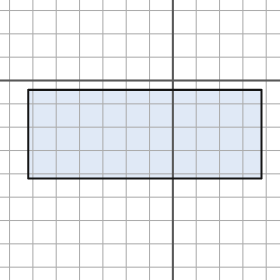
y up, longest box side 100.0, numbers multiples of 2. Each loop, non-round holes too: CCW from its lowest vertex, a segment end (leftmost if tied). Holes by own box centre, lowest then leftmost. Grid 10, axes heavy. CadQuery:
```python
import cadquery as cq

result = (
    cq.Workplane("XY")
    .moveTo(-62.0, -42.0)
    .lineTo(38.0, -42.0)
    .lineTo(38.0, -4.0)
    .lineTo(-62.0, -4.0)
    .close()
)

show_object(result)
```